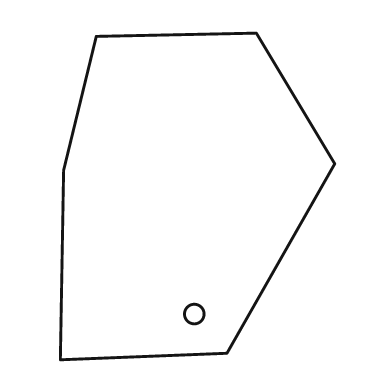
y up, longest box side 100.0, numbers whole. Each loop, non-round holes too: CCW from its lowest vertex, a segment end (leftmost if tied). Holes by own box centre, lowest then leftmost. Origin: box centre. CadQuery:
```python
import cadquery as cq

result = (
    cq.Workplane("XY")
    .moveTo(-42.0, -50.0)
    .lineTo(9.0, -48.0)
    .lineTo(42.0, 10.0)
    .lineTo(18.0, 50.0)
    .lineTo(-31.0, 49.0)
    .lineTo(-41.0, 8.0)
    .close()
    .moveTo(-1.0, -36.0)
    .circle(3.0)
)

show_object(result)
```